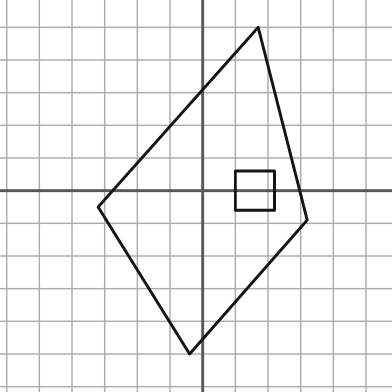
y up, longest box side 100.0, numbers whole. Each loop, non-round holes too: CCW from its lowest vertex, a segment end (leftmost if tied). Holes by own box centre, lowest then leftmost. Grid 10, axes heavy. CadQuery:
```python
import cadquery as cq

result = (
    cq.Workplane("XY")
    .moveTo(-4.0, -50.0)
    .lineTo(32.0, -9.0)
    .lineTo(17.0, 50.0)
    .lineTo(-32.0, -5.0)
    .close()
    .moveTo(10.0, -6.0)
    .lineTo(22.0, -6.0)
    .lineTo(22.0, 6.0)
    .lineTo(10.0, 6.0)
    .close()
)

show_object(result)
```